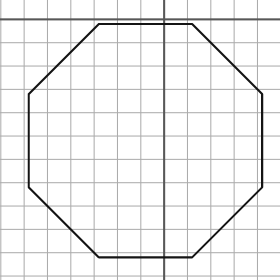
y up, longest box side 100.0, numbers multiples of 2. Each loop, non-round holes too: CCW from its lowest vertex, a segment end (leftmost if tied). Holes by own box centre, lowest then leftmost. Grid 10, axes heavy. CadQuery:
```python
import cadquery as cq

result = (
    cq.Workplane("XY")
    .moveTo(-28.0, -102.0)
    .lineTo(12.0, -102.0)
    .lineTo(42.0, -72.0)
    .lineTo(42.0, -32.0)
    .lineTo(12.0, -2.0)
    .lineTo(-28.0, -2.0)
    .lineTo(-58.0, -32.0)
    .lineTo(-58.0, -72.0)
    .close()
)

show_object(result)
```